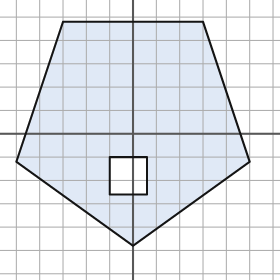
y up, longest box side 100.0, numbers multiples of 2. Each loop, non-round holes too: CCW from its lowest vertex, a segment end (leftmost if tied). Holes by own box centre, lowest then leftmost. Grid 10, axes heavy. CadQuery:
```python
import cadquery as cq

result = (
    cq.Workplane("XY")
    .moveTo(0.0, -48.0)
    .lineTo(50.0, -12.0)
    .lineTo(30.0, 48.0)
    .lineTo(-30.0, 48.0)
    .lineTo(-50.0, -12.0)
    .close()
    .moveTo(-10.0, -26.0)
    .lineTo(6.0, -26.0)
    .lineTo(6.0, -10.0)
    .lineTo(-10.0, -10.0)
    .close()
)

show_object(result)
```